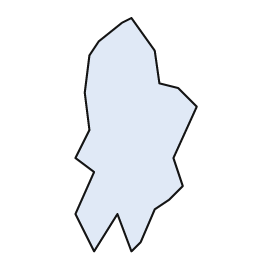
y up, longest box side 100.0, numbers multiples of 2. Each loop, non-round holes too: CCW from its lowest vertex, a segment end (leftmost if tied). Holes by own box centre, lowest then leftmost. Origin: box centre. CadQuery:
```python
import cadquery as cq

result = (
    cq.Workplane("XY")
    .moveTo(-18.0, -50.0)
    .lineTo(-8.0, -34.0)
    .lineTo(-2.0, -50.0)
    .lineTo(2.0, -46.0)
    .lineTo(8.0, -32.0)
    .lineTo(14.0, -28.0)
    .lineTo(20.0, -22.0)
    .lineTo(16.0, -10.0)
    .lineTo(26.0, 12.0)
    .lineTo(18.0, 20.0)
    .lineTo(10.0, 22.0)
    .lineTo(8.0, 36.0)
    .lineTo(-2.0, 50.0)
    .lineTo(-6.0, 48.0)
    .lineTo(-16.0, 40.0)
    .lineTo(-20.0, 34.0)
    .lineTo(-22.0, 18.0)
    .lineTo(-20.0, 2.0)
    .lineTo(-26.0, -10.0)
    .lineTo(-18.0, -16.0)
    .lineTo(-26.0, -34.0)
    .close()
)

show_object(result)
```